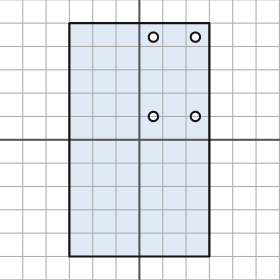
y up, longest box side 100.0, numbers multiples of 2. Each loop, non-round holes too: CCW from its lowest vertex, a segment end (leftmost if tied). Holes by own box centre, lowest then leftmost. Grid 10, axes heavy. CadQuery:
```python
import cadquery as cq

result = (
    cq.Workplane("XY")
    .moveTo(-30.0, -50.0)
    .lineTo(30.0, -50.0)
    .lineTo(30.0, 50.0)
    .lineTo(-30.0, 50.0)
    .close()
    .moveTo(6.0, 10.0)
    .circle(2.0)
    .moveTo(24.0, 10.0)
    .circle(2.0)
    .moveTo(6.0, 44.0)
    .circle(2.0)
    .moveTo(24.0, 44.0)
    .circle(2.0)
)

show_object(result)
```